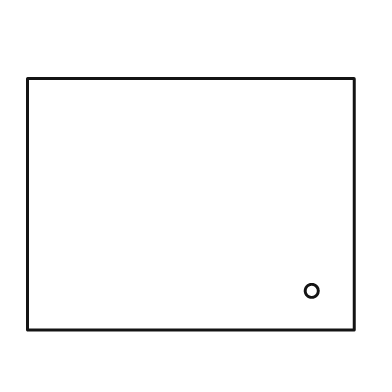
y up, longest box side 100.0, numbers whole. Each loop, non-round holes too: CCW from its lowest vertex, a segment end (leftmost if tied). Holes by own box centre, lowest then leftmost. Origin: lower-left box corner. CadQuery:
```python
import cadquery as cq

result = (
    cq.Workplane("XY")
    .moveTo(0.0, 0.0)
    .lineTo(100.0, 0.0)
    .lineTo(100.0, 77.0)
    .lineTo(0.0, 77.0)
    .close()
    .moveTo(87.0, 12.0)
    .circle(2.0)
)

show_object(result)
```